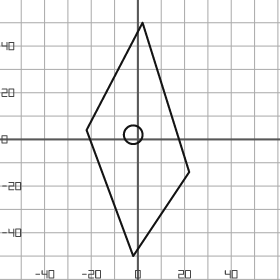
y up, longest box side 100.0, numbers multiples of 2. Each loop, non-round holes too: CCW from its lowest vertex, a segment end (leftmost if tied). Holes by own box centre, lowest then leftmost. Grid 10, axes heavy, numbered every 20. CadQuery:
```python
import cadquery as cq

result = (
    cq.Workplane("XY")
    .moveTo(-2.0, -50.0)
    .lineTo(22.0, -14.0)
    .lineTo(2.0, 50.0)
    .lineTo(-22.0, 4.0)
    .close()
    .moveTo(-2.0, 2.0)
    .circle(4.0)
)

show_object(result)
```